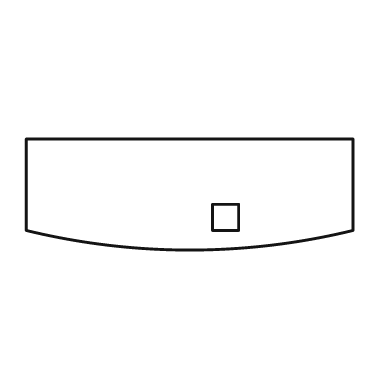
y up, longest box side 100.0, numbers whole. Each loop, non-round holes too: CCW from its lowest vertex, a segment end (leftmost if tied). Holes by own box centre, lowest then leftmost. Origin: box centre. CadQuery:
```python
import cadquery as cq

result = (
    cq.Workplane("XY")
    .moveTo(-50.0, -11.0)
    .threePointArc((0.0, -17.0), (50.0, -11.0))
    .lineTo(50.0, 17.0)
    .lineTo(-50.0, 17.0)
    .close()
    .moveTo(7.0, -11.0)
    .lineTo(15.0, -11.0)
    .lineTo(15.0, -3.0)
    .lineTo(7.0, -3.0)
    .close()
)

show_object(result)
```